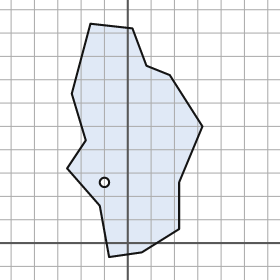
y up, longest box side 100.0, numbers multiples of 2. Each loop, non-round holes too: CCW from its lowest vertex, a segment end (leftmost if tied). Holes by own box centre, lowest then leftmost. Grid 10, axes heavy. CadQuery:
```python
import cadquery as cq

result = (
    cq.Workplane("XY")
    .moveTo(-8.0, -6.0)
    .lineTo(6.0, -4.0)
    .lineTo(22.0, 6.0)
    .lineTo(22.0, 26.0)
    .lineTo(32.0, 50.0)
    .lineTo(18.0, 72.0)
    .lineTo(8.0, 76.0)
    .lineTo(2.0, 92.0)
    .lineTo(-16.0, 94.0)
    .lineTo(-24.0, 64.0)
    .lineTo(-18.0, 44.0)
    .lineTo(-26.0, 32.0)
    .lineTo(-12.0, 16.0)
    .close()
    .moveTo(-10.0, 26.0)
    .circle(2.0)
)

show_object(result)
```